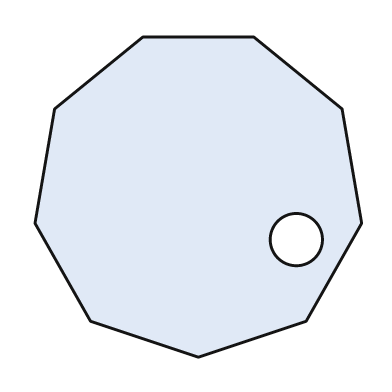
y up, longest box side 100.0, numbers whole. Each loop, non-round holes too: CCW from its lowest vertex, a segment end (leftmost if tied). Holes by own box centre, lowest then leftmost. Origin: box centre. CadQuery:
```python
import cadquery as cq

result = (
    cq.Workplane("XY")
    .moveTo(0.0, -49.0)
    .lineTo(33.0, -38.0)
    .lineTo(50.0, -8.0)
    .lineTo(44.0, 27.0)
    .lineTo(17.0, 49.0)
    .lineTo(-17.0, 49.0)
    .lineTo(-44.0, 27.0)
    .lineTo(-50.0, -8.0)
    .lineTo(-33.0, -38.0)
    .close()
    .moveTo(30.0, -13.0)
    .circle(8.0)
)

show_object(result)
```